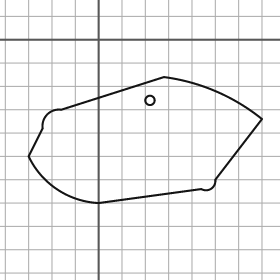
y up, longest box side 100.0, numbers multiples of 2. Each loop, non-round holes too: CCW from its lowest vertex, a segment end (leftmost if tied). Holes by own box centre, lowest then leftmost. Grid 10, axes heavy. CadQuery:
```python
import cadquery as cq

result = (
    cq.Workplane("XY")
    .moveTo(0.0, -70.0)
    .lineTo(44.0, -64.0)
    .threePointArc((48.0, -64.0), (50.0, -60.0))
    .lineTo(70.0, -34.0)
    .threePointArc((50.0, -22.0), (28.0, -16.0))
    .lineTo(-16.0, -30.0)
    .threePointArc((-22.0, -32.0), (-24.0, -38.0))
    .lineTo(-30.0, -50.0)
    .threePointArc((-18.0, -64.0), (0.0, -70.0))
    .close()
    .moveTo(22.0, -26.0)
    .circle(2.0)
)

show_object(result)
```